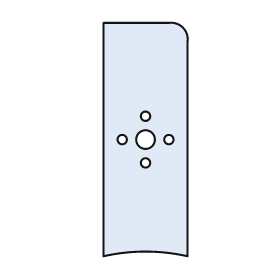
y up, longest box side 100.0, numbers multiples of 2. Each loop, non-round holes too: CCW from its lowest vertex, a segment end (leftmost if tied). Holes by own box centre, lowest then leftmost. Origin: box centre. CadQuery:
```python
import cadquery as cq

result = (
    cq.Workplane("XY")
    .moveTo(-18.0, -50.0)
    .threePointArc((0.0, -48.0), (18.0, -50.0))
    .lineTo(18.0, 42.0)
    .threePointArc((16.0, 48.0), (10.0, 50.0))
    .lineTo(-18.0, 50.0)
    .close()
    .moveTo(0.0, -10.0)
    .circle(2.0)
    .moveTo(-10.0, 0.0)
    .circle(2.0)
    .moveTo(0.0, 0.0)
    .circle(4.0)
    .moveTo(10.0, 0.0)
    .circle(2.0)
    .moveTo(0.0, 10.0)
    .circle(2.0)
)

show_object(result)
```